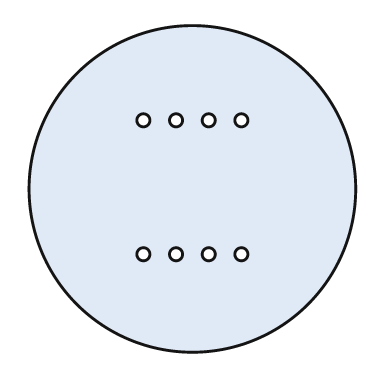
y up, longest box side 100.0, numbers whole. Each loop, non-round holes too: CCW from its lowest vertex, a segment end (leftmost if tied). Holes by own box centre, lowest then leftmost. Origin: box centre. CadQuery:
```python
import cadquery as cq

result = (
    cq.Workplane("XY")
    .moveTo(0.0, 0.0)
    .circle(50.0)
    .moveTo(-15.0, -20.0)
    .circle(2.0)
    .moveTo(-5.0, -20.0)
    .circle(2.0)
    .moveTo(5.0, -20.0)
    .circle(2.0)
    .moveTo(15.0, -20.0)
    .circle(2.0)
    .moveTo(-15.0, 21.0)
    .circle(2.0)
    .moveTo(-5.0, 21.0)
    .circle(2.0)
    .moveTo(5.0, 21.0)
    .circle(2.0)
    .moveTo(15.0, 21.0)
    .circle(2.0)
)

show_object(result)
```